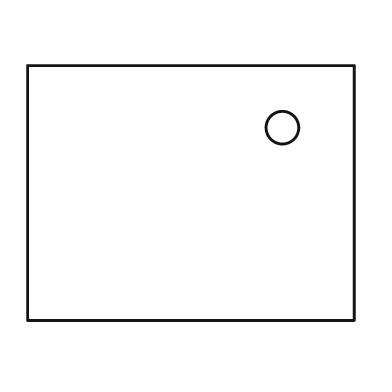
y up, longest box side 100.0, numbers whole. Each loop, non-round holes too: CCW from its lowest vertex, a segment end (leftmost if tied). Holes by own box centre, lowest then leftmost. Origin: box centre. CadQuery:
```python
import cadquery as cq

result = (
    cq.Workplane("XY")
    .moveTo(-50.0, -39.0)
    .lineTo(50.0, -39.0)
    .lineTo(50.0, 39.0)
    .lineTo(-50.0, 39.0)
    .close()
    .moveTo(28.0, 20.0)
    .circle(5.0)
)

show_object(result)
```